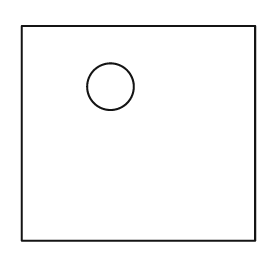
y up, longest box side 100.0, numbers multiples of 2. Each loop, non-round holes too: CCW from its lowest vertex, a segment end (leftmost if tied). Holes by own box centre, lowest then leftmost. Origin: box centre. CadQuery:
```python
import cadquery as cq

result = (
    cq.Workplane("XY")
    .moveTo(-50.0, -46.0)
    .lineTo(50.0, -46.0)
    .lineTo(50.0, 46.0)
    .lineTo(-50.0, 46.0)
    .close()
    .moveTo(-12.0, 20.0)
    .circle(10.0)
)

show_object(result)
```